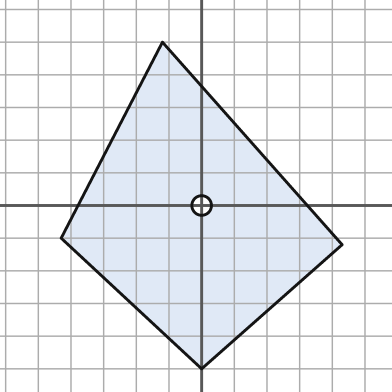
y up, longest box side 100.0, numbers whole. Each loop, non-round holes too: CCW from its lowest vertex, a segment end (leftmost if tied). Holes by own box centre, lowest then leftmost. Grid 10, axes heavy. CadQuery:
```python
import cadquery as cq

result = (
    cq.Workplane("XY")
    .moveTo(0.0, -50.0)
    .lineTo(43.0, -12.0)
    .lineTo(-12.0, 50.0)
    .lineTo(-43.0, -10.0)
    .close()
    .moveTo(0.0, 0.0)
    .circle(3.0)
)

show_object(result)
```